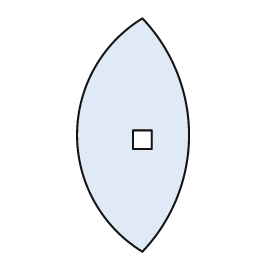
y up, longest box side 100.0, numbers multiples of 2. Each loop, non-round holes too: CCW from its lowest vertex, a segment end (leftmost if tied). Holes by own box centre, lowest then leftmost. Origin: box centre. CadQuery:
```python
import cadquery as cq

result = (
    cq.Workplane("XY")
    .moveTo(4.0, -50.0)
    .threePointArc((24.0, 0.0), (4.0, 50.0))
    .threePointArc((-24.0, 0.0), (4.0, -50.0))
    .close()
    .moveTo(0.0, -6.0)
    .lineTo(8.0, -6.0)
    .lineTo(8.0, 2.0)
    .lineTo(0.0, 2.0)
    .close()
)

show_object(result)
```